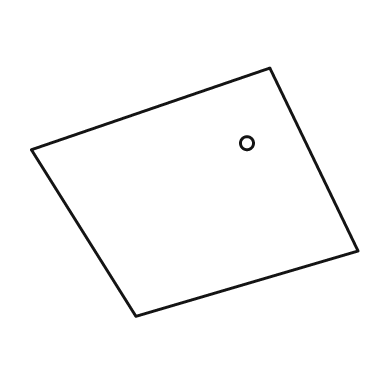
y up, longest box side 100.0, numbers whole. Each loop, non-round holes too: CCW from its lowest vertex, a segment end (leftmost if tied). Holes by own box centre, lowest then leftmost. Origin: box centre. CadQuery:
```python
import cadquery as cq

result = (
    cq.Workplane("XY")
    .moveTo(-18.0, -38.0)
    .lineTo(50.0, -18.0)
    .lineTo(23.0, 38.0)
    .lineTo(-50.0, 13.0)
    .close()
    .moveTo(16.0, 15.0)
    .circle(2.0)
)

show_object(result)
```